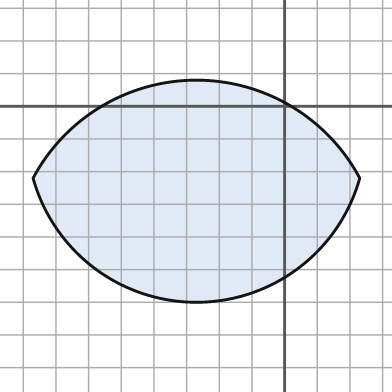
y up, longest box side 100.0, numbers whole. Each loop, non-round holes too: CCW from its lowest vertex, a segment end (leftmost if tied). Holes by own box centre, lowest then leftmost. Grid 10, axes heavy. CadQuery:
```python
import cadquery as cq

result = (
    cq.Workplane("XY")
    .moveTo(-77.0, -22.0)
    .threePointArc((-27.0, -60.0), (23.0, -22.0))
    .threePointArc((-27.0, 8.0), (-77.0, -22.0))
    .close()
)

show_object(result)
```